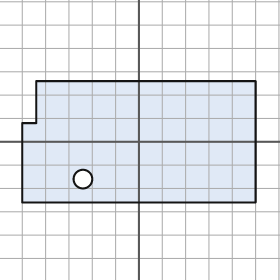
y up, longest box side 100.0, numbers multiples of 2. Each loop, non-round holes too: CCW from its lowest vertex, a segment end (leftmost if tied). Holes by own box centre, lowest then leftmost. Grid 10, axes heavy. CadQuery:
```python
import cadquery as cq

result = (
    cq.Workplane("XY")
    .moveTo(-50.0, -26.0)
    .lineTo(50.0, -26.0)
    .lineTo(50.0, 26.0)
    .lineTo(-44.0, 26.0)
    .lineTo(-44.0, 8.0)
    .lineTo(-50.0, 8.0)
    .close()
    .moveTo(-24.0, -16.0)
    .circle(4.0)
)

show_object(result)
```